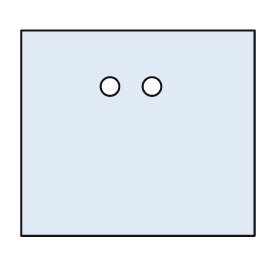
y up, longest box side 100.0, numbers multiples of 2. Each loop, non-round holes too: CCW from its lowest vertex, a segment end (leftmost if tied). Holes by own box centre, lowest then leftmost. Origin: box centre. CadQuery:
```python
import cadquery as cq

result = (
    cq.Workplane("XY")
    .moveTo(-50.0, -44.0)
    .lineTo(50.0, -44.0)
    .lineTo(50.0, 44.0)
    .lineTo(-50.0, 44.0)
    .close()
    .moveTo(-12.0, 20.0)
    .circle(4.0)
    .moveTo(6.0, 20.0)
    .circle(4.0)
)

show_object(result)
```